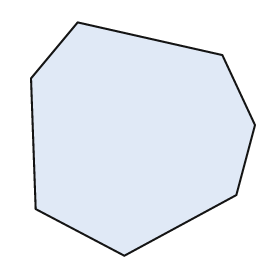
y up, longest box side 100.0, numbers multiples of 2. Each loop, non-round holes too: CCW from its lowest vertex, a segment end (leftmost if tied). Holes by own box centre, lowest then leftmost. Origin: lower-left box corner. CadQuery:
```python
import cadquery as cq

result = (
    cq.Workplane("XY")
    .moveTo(40.0, 0.0)
    .lineTo(88.0, 26.0)
    .lineTo(96.0, 56.0)
    .lineTo(82.0, 86.0)
    .lineTo(20.0, 100.0)
    .lineTo(0.0, 76.0)
    .lineTo(2.0, 20.0)
    .close()
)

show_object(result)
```